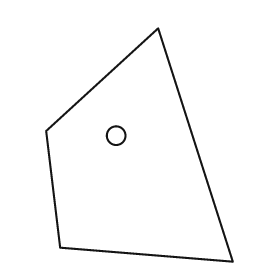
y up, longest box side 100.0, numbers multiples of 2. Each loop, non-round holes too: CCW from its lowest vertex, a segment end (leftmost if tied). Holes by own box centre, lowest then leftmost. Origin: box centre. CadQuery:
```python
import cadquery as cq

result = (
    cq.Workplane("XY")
    .moveTo(40.0, -50.0)
    .lineTo(8.0, 50.0)
    .lineTo(-40.0, 6.0)
    .lineTo(-34.0, -44.0)
    .close()
    .moveTo(-10.0, 4.0)
    .circle(4.0)
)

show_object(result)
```